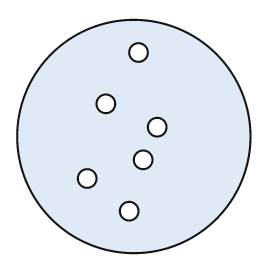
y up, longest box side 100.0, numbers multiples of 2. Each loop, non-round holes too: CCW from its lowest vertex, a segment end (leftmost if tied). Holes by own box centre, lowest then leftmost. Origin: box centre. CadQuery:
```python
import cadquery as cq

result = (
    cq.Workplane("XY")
    .moveTo(0.0, 0.0)
    .circle(50.0)
    .moveTo(-2.0, -32.0)
    .circle(4.0)
    .moveTo(-20.0, -18.0)
    .circle(4.0)
    .moveTo(4.0, -10.0)
    .circle(4.0)
    .moveTo(10.0, 4.0)
    .circle(4.0)
    .moveTo(-12.0, 14.0)
    .circle(4.0)
    .moveTo(2.0, 36.0)
    .circle(4.0)
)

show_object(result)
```